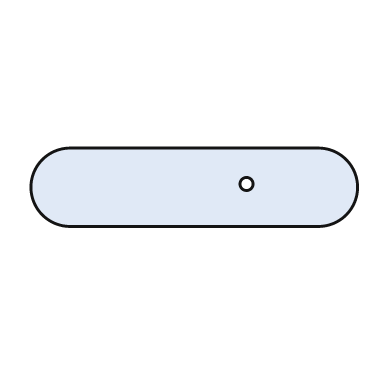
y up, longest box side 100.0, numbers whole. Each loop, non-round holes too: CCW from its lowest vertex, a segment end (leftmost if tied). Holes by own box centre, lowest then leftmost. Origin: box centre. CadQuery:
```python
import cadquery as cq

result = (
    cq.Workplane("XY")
    .moveTo(-38.0, -12.0)
    .lineTo(38.0, -12.0)
    .threePointArc((50.0, 0.0), (38.0, 12.0))
    .lineTo(-38.0, 12.0)
    .threePointArc((-50.0, 0.0), (-38.0, -12.0))
    .close()
    .moveTo(16.0, 1.0)
    .circle(2.0)
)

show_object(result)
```